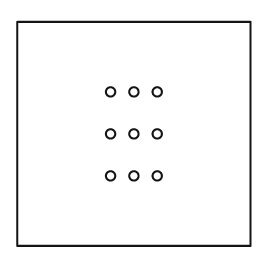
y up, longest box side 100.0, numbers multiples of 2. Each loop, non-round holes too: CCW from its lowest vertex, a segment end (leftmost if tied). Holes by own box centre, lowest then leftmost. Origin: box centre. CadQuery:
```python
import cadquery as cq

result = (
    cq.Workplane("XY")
    .moveTo(-50.0, -48.0)
    .lineTo(50.0, -48.0)
    .lineTo(50.0, 48.0)
    .lineTo(-50.0, 48.0)
    .close()
    .moveTo(-10.0, -18.0)
    .circle(2.0)
    .moveTo(0.0, -18.0)
    .circle(2.0)
    .moveTo(10.0, -18.0)
    .circle(2.0)
    .moveTo(-10.0, 0.0)
    .circle(2.0)
    .moveTo(0.0, 0.0)
    .circle(2.0)
    .moveTo(10.0, 0.0)
    .circle(2.0)
    .moveTo(-10.0, 18.0)
    .circle(2.0)
    .moveTo(0.0, 18.0)
    .circle(2.0)
    .moveTo(10.0, 18.0)
    .circle(2.0)
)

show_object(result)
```